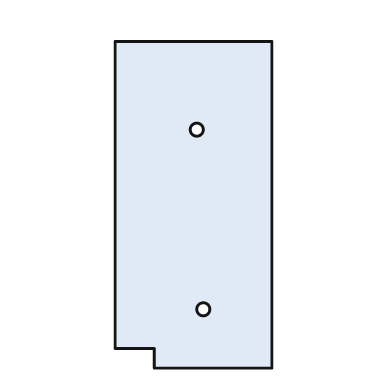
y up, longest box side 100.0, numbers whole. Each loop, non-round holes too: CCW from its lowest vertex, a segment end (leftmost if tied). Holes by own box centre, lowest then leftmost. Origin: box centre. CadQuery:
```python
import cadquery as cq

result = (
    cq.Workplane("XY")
    .moveTo(-12.0, -50.0)
    .lineTo(24.0, -50.0)
    .lineTo(24.0, 50.0)
    .lineTo(-24.0, 50.0)
    .lineTo(-24.0, -44.0)
    .lineTo(-12.0, -44.0)
    .close()
    .moveTo(3.0, -32.0)
    .circle(2.0)
    .moveTo(1.0, 23.0)
    .circle(2.0)
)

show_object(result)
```